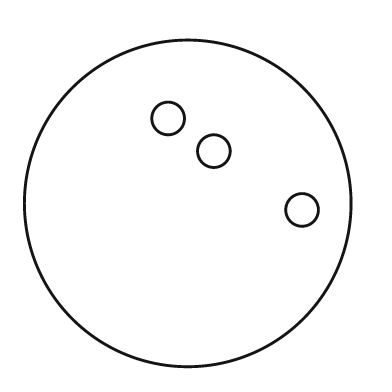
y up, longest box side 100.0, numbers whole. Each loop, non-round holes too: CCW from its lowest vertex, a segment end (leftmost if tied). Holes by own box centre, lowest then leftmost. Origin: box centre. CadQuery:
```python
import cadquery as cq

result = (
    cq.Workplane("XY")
    .moveTo(0.0, 0.0)
    .circle(50.0)
    .moveTo(35.0, -2.0)
    .circle(5.0)
    .moveTo(8.0, 16.0)
    .circle(5.0)
    .moveTo(-6.0, 26.0)
    .circle(5.0)
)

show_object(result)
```